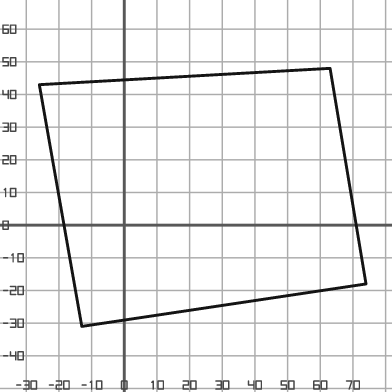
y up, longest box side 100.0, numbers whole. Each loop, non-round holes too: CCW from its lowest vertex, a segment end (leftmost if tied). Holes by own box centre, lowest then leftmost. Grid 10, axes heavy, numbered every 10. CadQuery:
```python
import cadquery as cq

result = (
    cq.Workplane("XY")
    .moveTo(-13.0, -31.0)
    .lineTo(74.0, -18.0)
    .lineTo(63.0, 48.0)
    .lineTo(-26.0, 43.0)
    .close()
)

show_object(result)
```